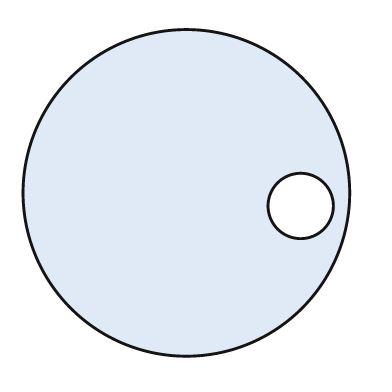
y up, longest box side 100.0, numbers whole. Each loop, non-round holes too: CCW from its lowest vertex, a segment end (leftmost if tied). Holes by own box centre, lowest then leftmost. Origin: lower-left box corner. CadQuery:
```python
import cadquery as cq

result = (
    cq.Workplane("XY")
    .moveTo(50.0, 50.0)
    .circle(50.0)
    .moveTo(85.0, 46.0)
    .circle(10.0)
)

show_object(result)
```